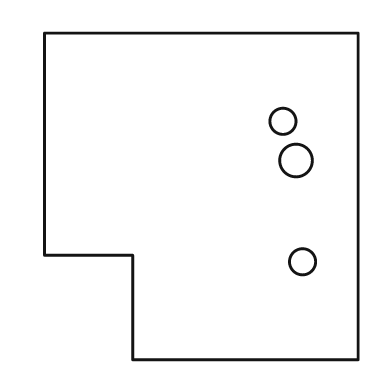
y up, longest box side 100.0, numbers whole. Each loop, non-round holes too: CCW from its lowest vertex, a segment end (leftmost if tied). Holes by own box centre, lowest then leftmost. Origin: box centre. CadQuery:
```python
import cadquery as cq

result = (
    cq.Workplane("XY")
    .moveTo(-21.0, -50.0)
    .lineTo(48.0, -50.0)
    .lineTo(48.0, 50.0)
    .lineTo(-48.0, 50.0)
    .lineTo(-48.0, -18.0)
    .lineTo(-21.0, -18.0)
    .close()
    .moveTo(31.0, -20.0)
    .circle(4.0)
    .moveTo(29.0, 11.0)
    .circle(5.0)
    .moveTo(25.0, 23.0)
    .circle(4.0)
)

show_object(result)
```